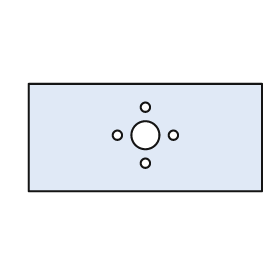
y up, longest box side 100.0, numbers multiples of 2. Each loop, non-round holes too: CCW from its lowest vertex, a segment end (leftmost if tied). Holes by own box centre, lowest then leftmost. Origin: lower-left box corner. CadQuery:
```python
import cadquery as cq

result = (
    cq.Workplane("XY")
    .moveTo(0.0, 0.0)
    .lineTo(100.0, 0.0)
    .lineTo(100.0, 46.0)
    .lineTo(0.0, 46.0)
    .close()
    .moveTo(50.0, 12.0)
    .circle(2.0)
    .moveTo(38.0, 24.0)
    .circle(2.0)
    .moveTo(50.0, 24.0)
    .circle(6.0)
    .moveTo(62.0, 24.0)
    .circle(2.0)
    .moveTo(50.0, 36.0)
    .circle(2.0)
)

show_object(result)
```